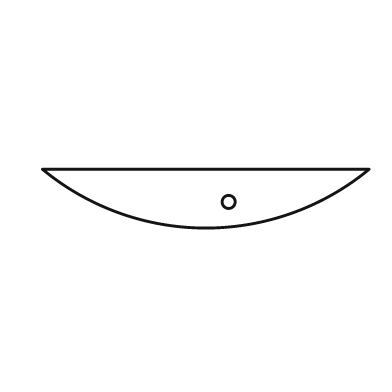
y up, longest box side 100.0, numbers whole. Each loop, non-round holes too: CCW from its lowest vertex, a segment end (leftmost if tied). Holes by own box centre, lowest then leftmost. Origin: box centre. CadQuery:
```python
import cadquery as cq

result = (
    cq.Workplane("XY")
    .moveTo(-50.0, 9.0)
    .threePointArc((0.0, -9.0), (50.0, 9.0))
    .close()
    .moveTo(7.0, -1.0)
    .circle(2.0)
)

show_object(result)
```